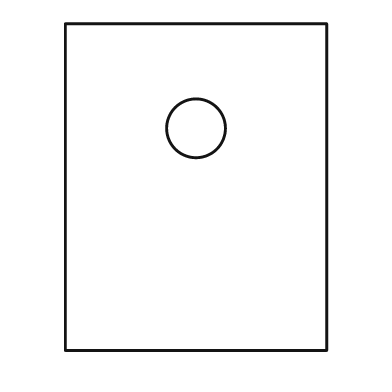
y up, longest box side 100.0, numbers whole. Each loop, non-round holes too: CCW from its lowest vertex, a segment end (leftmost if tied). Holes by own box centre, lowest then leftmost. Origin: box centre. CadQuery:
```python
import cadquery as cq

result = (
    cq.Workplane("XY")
    .moveTo(-40.0, -50.0)
    .lineTo(40.0, -50.0)
    .lineTo(40.0, 50.0)
    .lineTo(-40.0, 50.0)
    .close()
    .moveTo(0.0, 18.0)
    .circle(9.0)
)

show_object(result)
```